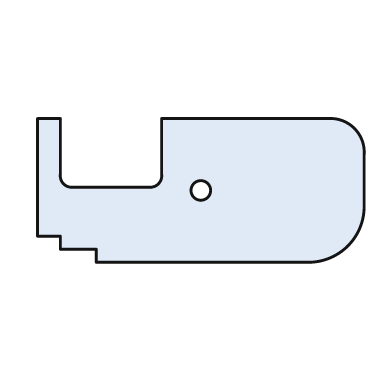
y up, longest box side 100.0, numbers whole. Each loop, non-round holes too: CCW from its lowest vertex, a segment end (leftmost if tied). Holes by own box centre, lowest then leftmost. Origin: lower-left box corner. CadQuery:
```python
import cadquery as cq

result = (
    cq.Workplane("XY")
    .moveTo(18.0, 0.0)
    .lineTo(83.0, 0.0)
    .threePointArc((95.0, 5.0), (100.0, 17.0))
    .lineTo(100.0, 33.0)
    .threePointArc((97.0, 41.0), (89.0, 44.0))
    .lineTo(38.0, 44.0)
    .lineTo(38.0, 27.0)
    .threePointArc((37.0, 24.0), (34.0, 23.0))
    .lineTo(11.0, 23.0)
    .threePointArc((8.0, 24.0), (7.0, 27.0))
    .lineTo(7.0, 44.0)
    .lineTo(0.0, 44.0)
    .lineTo(0.0, 8.0)
    .lineTo(7.0, 8.0)
    .lineTo(7.0, 4.0)
    .lineTo(18.0, 4.0)
    .close()
    .moveTo(50.0, 22.0)
    .circle(3.0)
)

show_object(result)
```